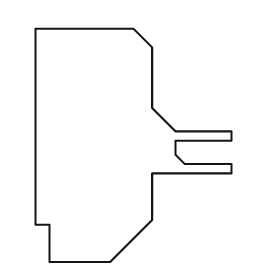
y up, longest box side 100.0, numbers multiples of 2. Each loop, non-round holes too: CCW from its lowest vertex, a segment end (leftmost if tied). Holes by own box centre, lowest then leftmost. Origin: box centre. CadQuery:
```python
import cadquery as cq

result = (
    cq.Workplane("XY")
    .moveTo(-36.0, -50.0)
    .lineTo(-10.0, -50.0)
    .lineTo(8.0, -32.0)
    .lineTo(8.0, -12.0)
    .lineTo(42.0, -12.0)
    .lineTo(42.0, -8.0)
    .lineTo(22.0, -8.0)
    .lineTo(18.0, -4.0)
    .lineTo(18.0, 2.0)
    .lineTo(42.0, 2.0)
    .lineTo(42.0, 6.0)
    .lineTo(18.0, 6.0)
    .lineTo(8.0, 16.0)
    .lineTo(8.0, 42.0)
    .lineTo(0.0, 50.0)
    .lineTo(-42.0, 50.0)
    .lineTo(-42.0, -34.0)
    .lineTo(-36.0, -34.0)
    .close()
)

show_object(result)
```